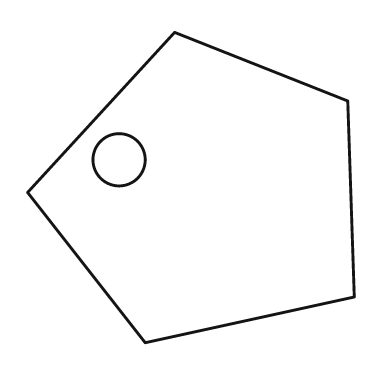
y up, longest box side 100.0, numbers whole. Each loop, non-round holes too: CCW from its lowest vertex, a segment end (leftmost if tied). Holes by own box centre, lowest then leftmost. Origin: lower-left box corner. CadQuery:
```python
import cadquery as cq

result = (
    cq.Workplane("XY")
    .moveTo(36.0, 0.0)
    .lineTo(100.0, 14.0)
    .lineTo(98.0, 74.0)
    .lineTo(45.0, 95.0)
    .lineTo(0.0, 46.0)
    .close()
    .moveTo(28.0, 56.0)
    .circle(8.0)
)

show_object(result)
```